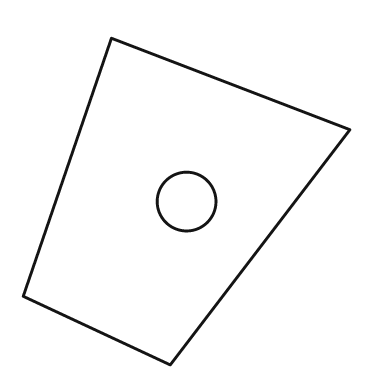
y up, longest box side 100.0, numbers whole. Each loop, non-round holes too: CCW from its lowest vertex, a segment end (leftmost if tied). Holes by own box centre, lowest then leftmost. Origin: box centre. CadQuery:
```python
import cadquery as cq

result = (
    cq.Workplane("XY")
    .moveTo(-5.0, -50.0)
    .lineTo(50.0, 22.0)
    .lineTo(-23.0, 50.0)
    .lineTo(-50.0, -29.0)
    .close()
    .moveTo(0.0, 0.0)
    .circle(9.0)
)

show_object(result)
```